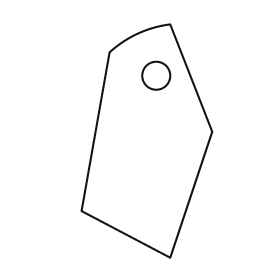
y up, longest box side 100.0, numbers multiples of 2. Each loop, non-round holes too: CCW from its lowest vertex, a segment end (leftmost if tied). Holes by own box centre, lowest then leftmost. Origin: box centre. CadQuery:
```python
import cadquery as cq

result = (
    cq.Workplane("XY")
    .moveTo(10.0, -50.0)
    .lineTo(28.0, 4.0)
    .lineTo(10.0, 50.0)
    .threePointArc((-4.0, 46.0), (-16.0, 38.0))
    .lineTo(-28.0, -30.0)
    .close()
    .moveTo(4.0, 28.0)
    .circle(6.0)
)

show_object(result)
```